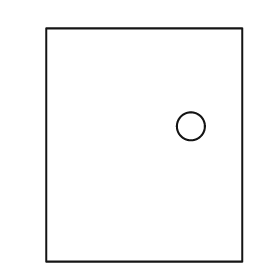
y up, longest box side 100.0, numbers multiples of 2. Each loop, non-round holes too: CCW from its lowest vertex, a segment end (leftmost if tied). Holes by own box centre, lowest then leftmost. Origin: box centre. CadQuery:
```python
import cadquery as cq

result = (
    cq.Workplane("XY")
    .moveTo(-42.0, -50.0)
    .lineTo(42.0, -50.0)
    .lineTo(42.0, 50.0)
    .lineTo(-42.0, 50.0)
    .close()
    .moveTo(20.0, 8.0)
    .circle(6.0)
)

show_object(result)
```